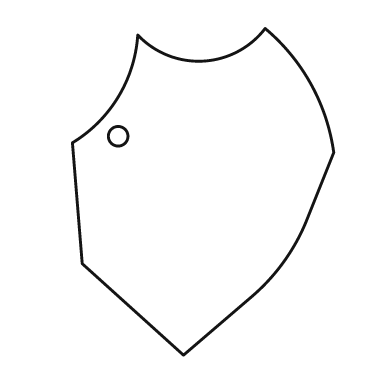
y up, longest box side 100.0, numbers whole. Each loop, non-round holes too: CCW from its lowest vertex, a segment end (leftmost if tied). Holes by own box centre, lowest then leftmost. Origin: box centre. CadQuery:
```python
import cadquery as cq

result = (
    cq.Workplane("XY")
    .moveTo(-6.0, -50.0)
    .lineTo(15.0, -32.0)
    .threePointArc((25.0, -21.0), (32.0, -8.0))
    .lineTo(40.0, 12.0)
    .threePointArc((33.0, 33.0), (19.0, 50.0))
    .threePointArc((0.0, 40.0), (-20.0, 48.0))
    .threePointArc((-26.0, 29.0), (-40.0, 15.0))
    .lineTo(-37.0, -22.0)
    .close()
    .moveTo(-26.0, 17.0)
    .circle(3.0)
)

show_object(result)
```